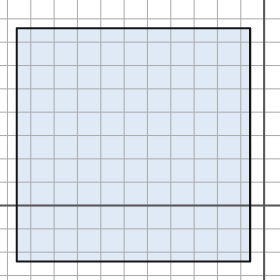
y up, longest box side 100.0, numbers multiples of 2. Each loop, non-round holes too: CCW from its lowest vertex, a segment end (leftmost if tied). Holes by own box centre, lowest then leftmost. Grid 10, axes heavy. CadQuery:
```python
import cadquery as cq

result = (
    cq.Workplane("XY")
    .moveTo(-106.0, -24.0)
    .lineTo(-6.0, -24.0)
    .lineTo(-6.0, 76.0)
    .lineTo(-106.0, 76.0)
    .close()
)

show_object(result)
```